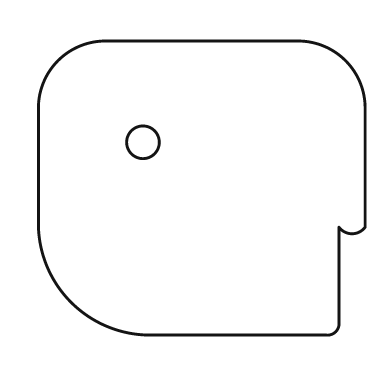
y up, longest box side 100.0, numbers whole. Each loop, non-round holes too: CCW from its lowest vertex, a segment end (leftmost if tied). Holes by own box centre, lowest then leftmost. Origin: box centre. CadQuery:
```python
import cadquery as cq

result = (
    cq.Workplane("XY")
    .moveTo(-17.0, -45.0)
    .lineTo(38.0, -45.0)
    .threePointArc((41.0, -44.0), (42.0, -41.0))
    .lineTo(42.0, -12.0)
    .threePointArc((46.0, -14.0), (50.0, -12.0))
    .lineTo(50.0, 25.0)
    .threePointArc((44.0, 39.0), (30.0, 45.0))
    .lineTo(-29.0, 45.0)
    .threePointArc((-44.0, 39.0), (-50.0, 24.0))
    .lineTo(-50.0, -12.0)
    .threePointArc((-40.0, -35.0), (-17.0, -45.0))
    .close()
    .moveTo(-18.0, 14.0)
    .circle(5.0)
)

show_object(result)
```